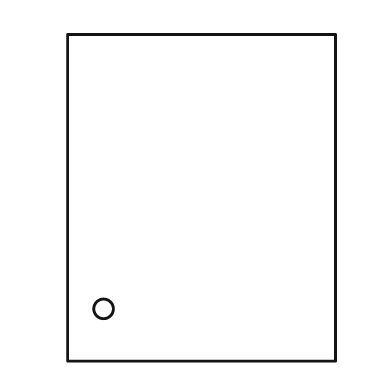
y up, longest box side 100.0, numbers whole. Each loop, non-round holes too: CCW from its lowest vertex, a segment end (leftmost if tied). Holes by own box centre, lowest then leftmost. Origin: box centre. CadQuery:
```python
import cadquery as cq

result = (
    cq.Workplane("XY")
    .moveTo(-41.0, -50.0)
    .lineTo(41.0, -50.0)
    .lineTo(41.0, 50.0)
    .lineTo(-41.0, 50.0)
    .close()
    .moveTo(-30.0, -34.0)
    .circle(3.0)
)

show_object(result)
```